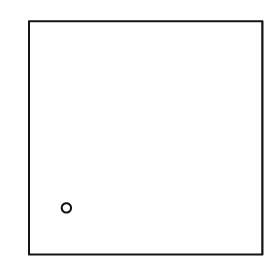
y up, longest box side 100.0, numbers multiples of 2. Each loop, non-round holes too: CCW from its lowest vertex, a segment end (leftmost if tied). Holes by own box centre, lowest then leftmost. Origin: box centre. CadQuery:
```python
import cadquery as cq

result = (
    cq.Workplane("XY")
    .moveTo(-50.0, -50.0)
    .lineTo(50.0, -50.0)
    .lineTo(50.0, 50.0)
    .lineTo(-50.0, 50.0)
    .close()
    .moveTo(-34.0, -30.0)
    .circle(2.0)
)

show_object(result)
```